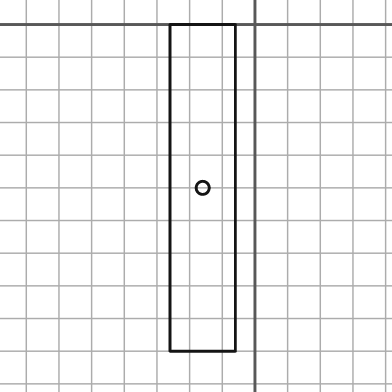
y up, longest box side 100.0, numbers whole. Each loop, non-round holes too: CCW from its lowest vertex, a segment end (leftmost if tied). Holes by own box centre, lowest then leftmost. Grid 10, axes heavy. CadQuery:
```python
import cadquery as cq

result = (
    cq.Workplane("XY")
    .moveTo(-26.0, -100.0)
    .lineTo(-6.0, -100.0)
    .lineTo(-6.0, 0.0)
    .lineTo(-26.0, 0.0)
    .close()
    .moveTo(-16.0, -50.0)
    .circle(2.0)
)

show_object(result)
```